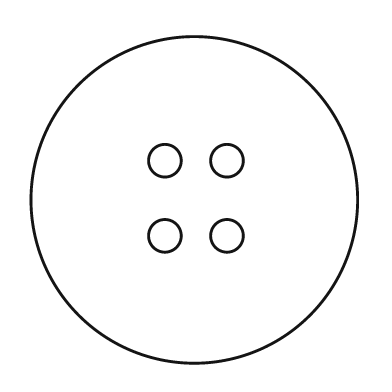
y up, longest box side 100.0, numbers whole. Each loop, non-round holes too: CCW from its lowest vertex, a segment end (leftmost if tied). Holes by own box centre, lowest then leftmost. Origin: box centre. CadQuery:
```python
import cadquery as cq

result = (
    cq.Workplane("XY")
    .moveTo(0.0, 0.0)
    .circle(50.0)
    .moveTo(-9.0, -11.0)
    .circle(5.0)
    .moveTo(10.0, -11.0)
    .circle(5.0)
    .moveTo(-9.0, 12.0)
    .circle(5.0)
    .moveTo(10.0, 12.0)
    .circle(5.0)
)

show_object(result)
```